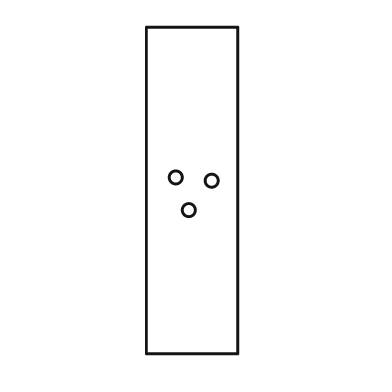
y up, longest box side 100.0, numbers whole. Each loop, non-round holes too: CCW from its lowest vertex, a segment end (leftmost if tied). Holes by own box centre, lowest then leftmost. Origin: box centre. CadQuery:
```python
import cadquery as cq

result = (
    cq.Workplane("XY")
    .moveTo(-14.0, -50.0)
    .lineTo(14.0, -50.0)
    .lineTo(14.0, 50.0)
    .lineTo(-14.0, 50.0)
    .close()
    .moveTo(-1.0, -6.0)
    .circle(2.0)
    .moveTo(6.0, 3.0)
    .circle(2.0)
    .moveTo(-5.0, 4.0)
    .circle(2.0)
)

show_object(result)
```